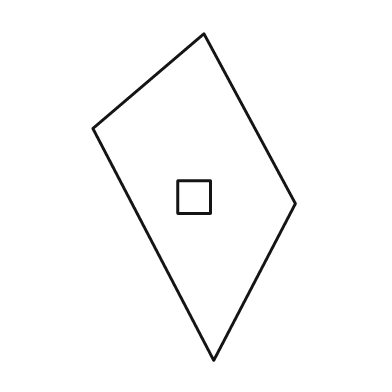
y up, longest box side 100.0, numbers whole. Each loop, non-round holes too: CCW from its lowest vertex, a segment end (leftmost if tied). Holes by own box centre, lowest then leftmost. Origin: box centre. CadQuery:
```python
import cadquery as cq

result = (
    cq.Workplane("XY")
    .moveTo(6.0, -50.0)
    .lineTo(31.0, -2.0)
    .lineTo(3.0, 50.0)
    .lineTo(-31.0, 21.0)
    .close()
    .moveTo(-5.0, -5.0)
    .lineTo(5.0, -5.0)
    .lineTo(5.0, 5.0)
    .lineTo(-5.0, 5.0)
    .close()
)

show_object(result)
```